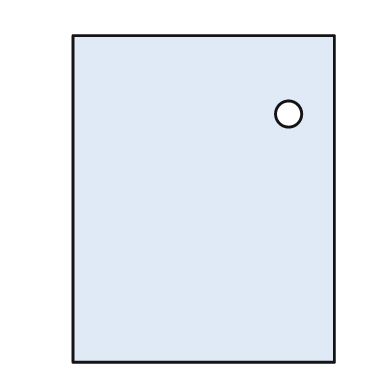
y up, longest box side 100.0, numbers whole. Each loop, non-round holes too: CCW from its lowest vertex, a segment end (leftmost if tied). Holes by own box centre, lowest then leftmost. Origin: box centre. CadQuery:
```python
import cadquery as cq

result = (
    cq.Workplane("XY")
    .moveTo(-40.0, -50.0)
    .lineTo(40.0, -50.0)
    .lineTo(40.0, 50.0)
    .lineTo(-40.0, 50.0)
    .close()
    .moveTo(26.0, 26.0)
    .circle(4.0)
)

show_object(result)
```